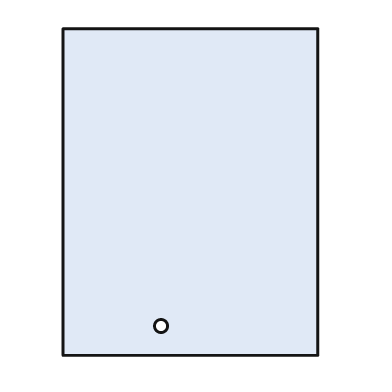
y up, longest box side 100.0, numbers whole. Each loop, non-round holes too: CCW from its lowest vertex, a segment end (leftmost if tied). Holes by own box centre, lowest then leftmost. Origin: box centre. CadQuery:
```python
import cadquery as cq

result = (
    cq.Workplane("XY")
    .moveTo(-39.0, -50.0)
    .lineTo(39.0, -50.0)
    .lineTo(39.0, 50.0)
    .lineTo(-39.0, 50.0)
    .close()
    .moveTo(-9.0, -41.0)
    .circle(2.0)
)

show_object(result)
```